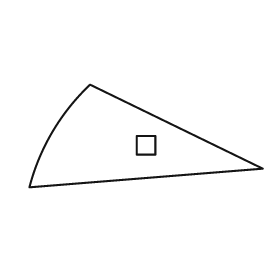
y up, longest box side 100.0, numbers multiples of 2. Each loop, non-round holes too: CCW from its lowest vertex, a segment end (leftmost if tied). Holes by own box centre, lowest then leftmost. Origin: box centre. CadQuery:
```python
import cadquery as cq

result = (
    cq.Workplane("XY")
    .moveTo(-50.0, -22.0)
    .lineTo(50.0, -14.0)
    .lineTo(-24.0, 22.0)
    .threePointArc((-40.0, 2.0), (-50.0, -22.0))
    .close()
    .moveTo(-4.0, -8.0)
    .lineTo(4.0, -8.0)
    .lineTo(4.0, 0.0)
    .lineTo(-4.0, 0.0)
    .close()
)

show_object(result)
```